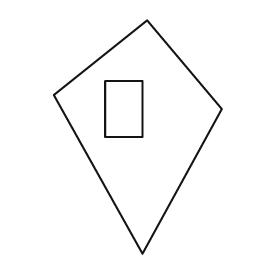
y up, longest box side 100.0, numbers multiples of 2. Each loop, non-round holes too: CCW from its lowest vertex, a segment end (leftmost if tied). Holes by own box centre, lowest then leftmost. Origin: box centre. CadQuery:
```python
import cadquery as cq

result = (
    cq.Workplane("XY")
    .moveTo(2.0, -50.0)
    .lineTo(36.0, 12.0)
    .lineTo(4.0, 50.0)
    .lineTo(-36.0, 18.0)
    .close()
    .moveTo(-14.0, 0.0)
    .lineTo(2.0, 0.0)
    .lineTo(2.0, 24.0)
    .lineTo(-14.0, 24.0)
    .close()
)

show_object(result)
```